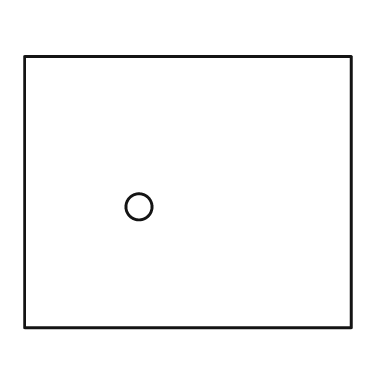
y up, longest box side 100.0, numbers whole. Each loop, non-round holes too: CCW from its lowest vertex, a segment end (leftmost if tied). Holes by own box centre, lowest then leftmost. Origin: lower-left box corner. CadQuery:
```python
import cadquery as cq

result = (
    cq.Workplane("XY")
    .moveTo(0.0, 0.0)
    .lineTo(100.0, 0.0)
    .lineTo(100.0, 83.0)
    .lineTo(0.0, 83.0)
    .close()
    .moveTo(35.0, 37.0)
    .circle(4.0)
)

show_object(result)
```